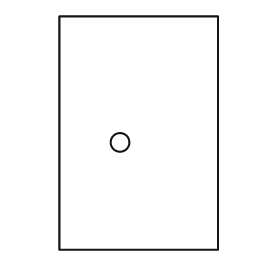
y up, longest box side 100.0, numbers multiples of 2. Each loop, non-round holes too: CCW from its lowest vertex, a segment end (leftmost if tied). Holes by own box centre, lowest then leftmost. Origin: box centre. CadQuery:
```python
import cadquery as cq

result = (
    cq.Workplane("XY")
    .moveTo(-34.0, -50.0)
    .lineTo(34.0, -50.0)
    .lineTo(34.0, 50.0)
    .lineTo(-34.0, 50.0)
    .close()
    .moveTo(-8.0, -4.0)
    .circle(4.0)
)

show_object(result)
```